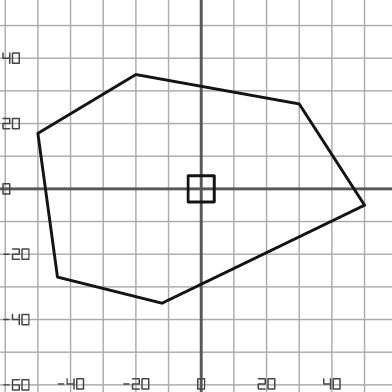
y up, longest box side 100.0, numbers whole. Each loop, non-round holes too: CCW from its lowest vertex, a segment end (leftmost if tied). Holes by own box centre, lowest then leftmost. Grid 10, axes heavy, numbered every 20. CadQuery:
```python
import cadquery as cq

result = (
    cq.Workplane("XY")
    .moveTo(-12.0, -35.0)
    .lineTo(50.0, -5.0)
    .lineTo(30.0, 26.0)
    .lineTo(-20.0, 35.0)
    .lineTo(-50.0, 17.0)
    .lineTo(-44.0, -27.0)
    .close()
    .moveTo(-4.0, -4.0)
    .lineTo(4.0, -4.0)
    .lineTo(4.0, 4.0)
    .lineTo(-4.0, 4.0)
    .close()
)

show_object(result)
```